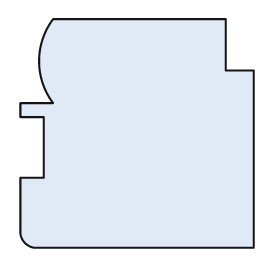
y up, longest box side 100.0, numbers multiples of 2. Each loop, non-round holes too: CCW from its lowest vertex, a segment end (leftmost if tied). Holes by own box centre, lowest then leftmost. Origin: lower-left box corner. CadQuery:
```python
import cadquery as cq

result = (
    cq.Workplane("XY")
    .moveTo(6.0, 0.0)
    .lineTo(100.0, 0.0)
    .lineTo(100.0, 76.0)
    .lineTo(88.0, 76.0)
    .lineTo(88.0, 98.0)
    .lineTo(14.0, 98.0)
    .threePointArc((8.0, 80.0), (14.0, 62.0))
    .lineTo(0.0, 62.0)
    .lineTo(0.0, 56.0)
    .lineTo(10.0, 56.0)
    .lineTo(10.0, 30.0)
    .lineTo(0.0, 30.0)
    .lineTo(0.0, 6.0)
    .threePointArc((2.0, 2.0), (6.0, 0.0))
    .close()
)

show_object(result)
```